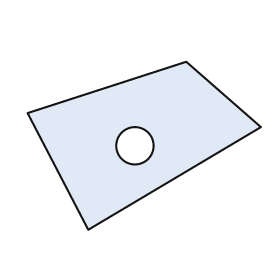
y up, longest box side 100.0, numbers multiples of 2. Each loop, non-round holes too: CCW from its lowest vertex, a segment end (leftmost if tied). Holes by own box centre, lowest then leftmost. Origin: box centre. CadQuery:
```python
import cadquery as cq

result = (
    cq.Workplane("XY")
    .moveTo(-24.0, -36.0)
    .lineTo(50.0, 8.0)
    .lineTo(18.0, 36.0)
    .lineTo(-50.0, 14.0)
    .close()
    .moveTo(-4.0, 0.0)
    .circle(8.0)
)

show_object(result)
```